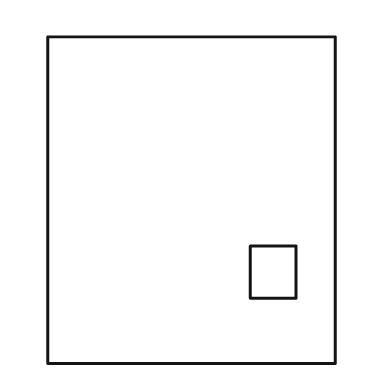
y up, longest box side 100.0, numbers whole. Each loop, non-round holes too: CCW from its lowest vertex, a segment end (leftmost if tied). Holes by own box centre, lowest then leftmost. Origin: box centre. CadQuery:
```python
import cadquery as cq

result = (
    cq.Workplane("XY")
    .moveTo(-44.0, -50.0)
    .lineTo(44.0, -50.0)
    .lineTo(44.0, 50.0)
    .lineTo(-44.0, 50.0)
    .close()
    .moveTo(18.0, -30.0)
    .lineTo(32.0, -30.0)
    .lineTo(32.0, -14.0)
    .lineTo(18.0, -14.0)
    .close()
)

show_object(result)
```